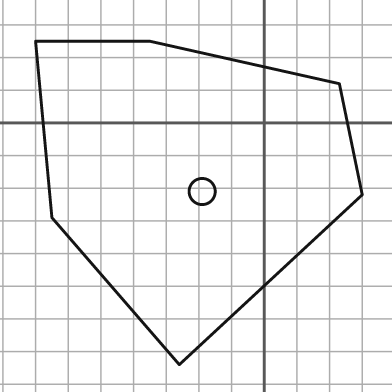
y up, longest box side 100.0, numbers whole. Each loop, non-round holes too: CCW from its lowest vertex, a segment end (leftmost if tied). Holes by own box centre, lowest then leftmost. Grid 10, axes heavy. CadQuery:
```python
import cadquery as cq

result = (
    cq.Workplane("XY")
    .moveTo(-26.0, -74.0)
    .lineTo(30.0, -22.0)
    .lineTo(23.0, 12.0)
    .lineTo(-35.0, 25.0)
    .lineTo(-70.0, 25.0)
    .lineTo(-65.0, -29.0)
    .close()
    .moveTo(-19.0, -21.0)
    .circle(4.0)
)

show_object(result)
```